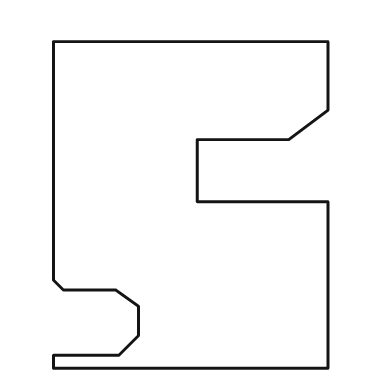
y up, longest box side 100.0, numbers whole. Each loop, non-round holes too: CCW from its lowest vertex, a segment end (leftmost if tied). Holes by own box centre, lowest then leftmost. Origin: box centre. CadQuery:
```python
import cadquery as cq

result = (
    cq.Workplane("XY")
    .moveTo(-42.0, -50.0)
    .lineTo(42.0, -50.0)
    .lineTo(42.0, 1.0)
    .lineTo(2.0, 1.0)
    .lineTo(2.0, 20.0)
    .lineTo(30.0, 20.0)
    .lineTo(42.0, 29.0)
    .lineTo(42.0, 50.0)
    .lineTo(-42.0, 50.0)
    .lineTo(-42.0, -23.0)
    .lineTo(-39.0, -26.0)
    .lineTo(-23.0, -26.0)
    .lineTo(-16.0, -31.0)
    .lineTo(-16.0, -40.0)
    .lineTo(-22.0, -46.0)
    .lineTo(-42.0, -46.0)
    .close()
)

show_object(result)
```